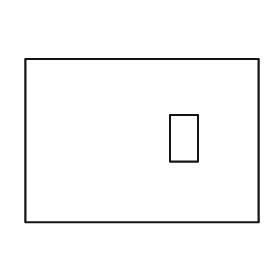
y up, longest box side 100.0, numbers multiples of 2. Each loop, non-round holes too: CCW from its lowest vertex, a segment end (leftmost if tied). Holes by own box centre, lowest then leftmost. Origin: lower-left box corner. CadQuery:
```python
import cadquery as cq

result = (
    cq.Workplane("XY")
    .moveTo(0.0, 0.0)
    .lineTo(100.0, 0.0)
    .lineTo(100.0, 70.0)
    .lineTo(0.0, 70.0)
    .close()
    .moveTo(62.0, 26.0)
    .lineTo(74.0, 26.0)
    .lineTo(74.0, 46.0)
    .lineTo(62.0, 46.0)
    .close()
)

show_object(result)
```